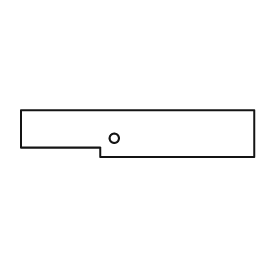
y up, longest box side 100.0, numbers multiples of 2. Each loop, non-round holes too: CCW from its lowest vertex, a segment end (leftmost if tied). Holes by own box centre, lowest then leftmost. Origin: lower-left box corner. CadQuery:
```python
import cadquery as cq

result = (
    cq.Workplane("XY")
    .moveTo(34.0, 0.0)
    .lineTo(100.0, 0.0)
    .lineTo(100.0, 20.0)
    .lineTo(0.0, 20.0)
    .lineTo(0.0, 4.0)
    .lineTo(34.0, 4.0)
    .close()
    .moveTo(40.0, 8.0)
    .circle(2.0)
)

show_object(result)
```